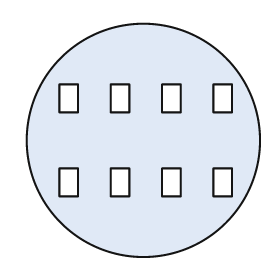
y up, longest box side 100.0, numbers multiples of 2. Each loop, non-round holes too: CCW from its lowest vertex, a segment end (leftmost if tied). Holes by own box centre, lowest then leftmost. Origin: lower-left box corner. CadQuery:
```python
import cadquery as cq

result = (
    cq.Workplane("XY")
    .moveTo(50.0, 50.0)
    .circle(50.0)
    .moveTo(14.0, 26.0)
    .lineTo(22.0, 26.0)
    .lineTo(22.0, 38.0)
    .lineTo(14.0, 38.0)
    .close()
    .moveTo(36.0, 26.0)
    .lineTo(44.0, 26.0)
    .lineTo(44.0, 38.0)
    .lineTo(36.0, 38.0)
    .close()
    .moveTo(58.0, 26.0)
    .lineTo(66.0, 26.0)
    .lineTo(66.0, 38.0)
    .lineTo(58.0, 38.0)
    .close()
    .moveTo(80.0, 26.0)
    .lineTo(88.0, 26.0)
    .lineTo(88.0, 38.0)
    .lineTo(80.0, 38.0)
    .close()
    .moveTo(14.0, 62.0)
    .lineTo(22.0, 62.0)
    .lineTo(22.0, 74.0)
    .lineTo(14.0, 74.0)
    .close()
    .moveTo(36.0, 62.0)
    .lineTo(44.0, 62.0)
    .lineTo(44.0, 74.0)
    .lineTo(36.0, 74.0)
    .close()
    .moveTo(58.0, 62.0)
    .lineTo(66.0, 62.0)
    .lineTo(66.0, 74.0)
    .lineTo(58.0, 74.0)
    .close()
    .moveTo(80.0, 62.0)
    .lineTo(88.0, 62.0)
    .lineTo(88.0, 74.0)
    .lineTo(80.0, 74.0)
    .close()
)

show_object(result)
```